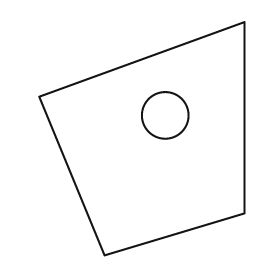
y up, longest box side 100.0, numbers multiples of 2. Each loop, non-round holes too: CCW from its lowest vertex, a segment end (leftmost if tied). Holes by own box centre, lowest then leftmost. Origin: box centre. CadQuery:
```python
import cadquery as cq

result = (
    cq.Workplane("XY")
    .moveTo(-16.0, -50.0)
    .lineTo(44.0, -32.0)
    .lineTo(44.0, 50.0)
    .lineTo(-44.0, 18.0)
    .close()
    .moveTo(10.0, 10.0)
    .circle(10.0)
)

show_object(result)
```